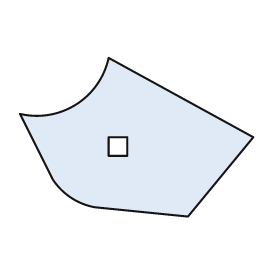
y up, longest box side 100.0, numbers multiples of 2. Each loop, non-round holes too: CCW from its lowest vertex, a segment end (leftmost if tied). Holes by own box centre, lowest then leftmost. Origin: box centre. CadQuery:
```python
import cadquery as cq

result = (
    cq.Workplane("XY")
    .moveTo(22.0, -34.0)
    .lineTo(50.0, 0.0)
    .lineTo(-12.0, 34.0)
    .threePointArc((-26.0, 14.0), (-50.0, 10.0))
    .lineTo(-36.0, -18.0)
    .threePointArc((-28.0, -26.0), (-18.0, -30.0))
    .close()
    .moveTo(-12.0, -8.0)
    .lineTo(-4.0, -8.0)
    .lineTo(-4.0, 0.0)
    .lineTo(-12.0, 0.0)
    .close()
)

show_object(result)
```